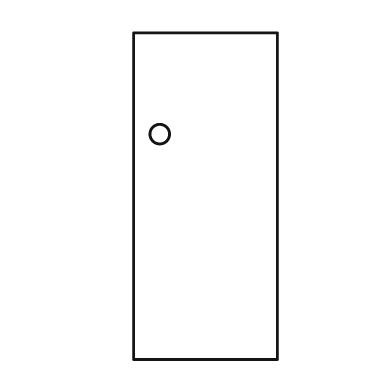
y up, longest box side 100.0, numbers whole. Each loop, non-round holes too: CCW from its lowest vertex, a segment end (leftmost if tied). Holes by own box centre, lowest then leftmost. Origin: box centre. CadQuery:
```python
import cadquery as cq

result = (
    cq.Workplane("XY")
    .moveTo(-22.0, -50.0)
    .lineTo(22.0, -50.0)
    .lineTo(22.0, 50.0)
    .lineTo(-22.0, 50.0)
    .close()
    .moveTo(-14.0, 19.0)
    .circle(3.0)
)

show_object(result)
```